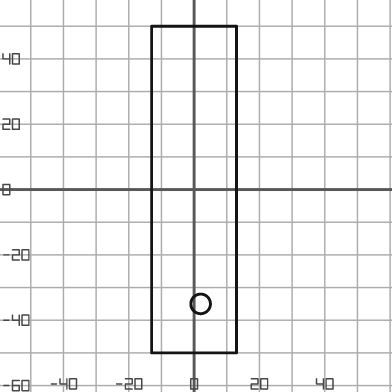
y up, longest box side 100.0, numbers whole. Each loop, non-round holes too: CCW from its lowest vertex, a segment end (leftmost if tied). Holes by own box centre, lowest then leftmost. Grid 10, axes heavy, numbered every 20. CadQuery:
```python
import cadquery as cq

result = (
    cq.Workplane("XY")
    .moveTo(-13.0, -50.0)
    .lineTo(13.0, -50.0)
    .lineTo(13.0, 50.0)
    .lineTo(-13.0, 50.0)
    .close()
    .moveTo(2.0, -35.0)
    .circle(3.0)
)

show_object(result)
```